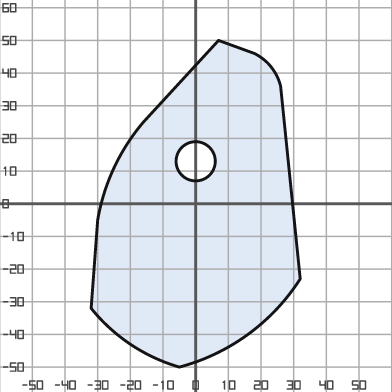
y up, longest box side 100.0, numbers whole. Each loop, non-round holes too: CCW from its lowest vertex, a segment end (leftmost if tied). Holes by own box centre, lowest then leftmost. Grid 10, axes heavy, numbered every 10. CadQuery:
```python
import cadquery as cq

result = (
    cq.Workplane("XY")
    .moveTo(-5.0, -50.0)
    .threePointArc((16.0, -40.0), (32.0, -23.0))
    .lineTo(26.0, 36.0)
    .threePointArc((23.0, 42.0), (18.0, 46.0))
    .lineTo(7.0, 50.0)
    .lineTo(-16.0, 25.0)
    .threePointArc((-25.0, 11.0), (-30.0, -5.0))
    .lineTo(-32.0, -32.0)
    .threePointArc((-20.0, -43.0), (-5.0, -50.0))
    .close()
    .moveTo(0.0, 13.0)
    .circle(6.0)
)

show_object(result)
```